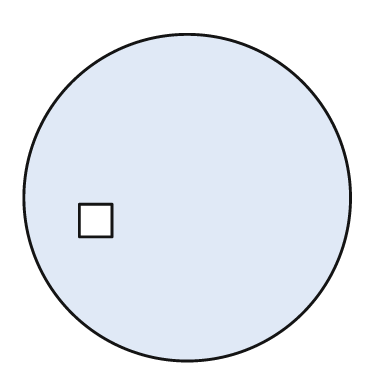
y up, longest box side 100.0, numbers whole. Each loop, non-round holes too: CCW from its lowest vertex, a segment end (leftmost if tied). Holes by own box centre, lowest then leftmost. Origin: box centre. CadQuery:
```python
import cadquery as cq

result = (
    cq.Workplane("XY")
    .moveTo(0.0, 0.0)
    .circle(50.0)
    .moveTo(-33.0, -12.0)
    .lineTo(-23.0, -12.0)
    .lineTo(-23.0, -2.0)
    .lineTo(-33.0, -2.0)
    .close()
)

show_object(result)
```